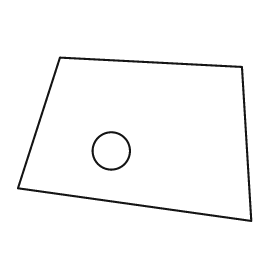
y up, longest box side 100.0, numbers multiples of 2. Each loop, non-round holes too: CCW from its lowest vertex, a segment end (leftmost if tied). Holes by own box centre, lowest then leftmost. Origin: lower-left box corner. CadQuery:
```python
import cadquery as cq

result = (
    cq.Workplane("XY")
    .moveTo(100.0, 0.0)
    .lineTo(96.0, 66.0)
    .lineTo(18.0, 70.0)
    .lineTo(0.0, 14.0)
    .close()
    .moveTo(40.0, 30.0)
    .circle(8.0)
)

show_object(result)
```